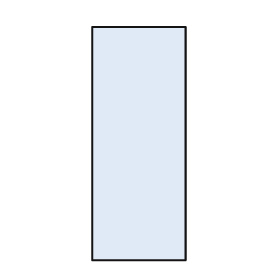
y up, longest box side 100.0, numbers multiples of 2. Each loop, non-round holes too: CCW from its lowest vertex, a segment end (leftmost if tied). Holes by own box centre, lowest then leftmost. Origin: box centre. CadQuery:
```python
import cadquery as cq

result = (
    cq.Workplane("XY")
    .moveTo(-20.0, -50.0)
    .lineTo(20.0, -50.0)
    .lineTo(20.0, 50.0)
    .lineTo(-20.0, 50.0)
    .close()
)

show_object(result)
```